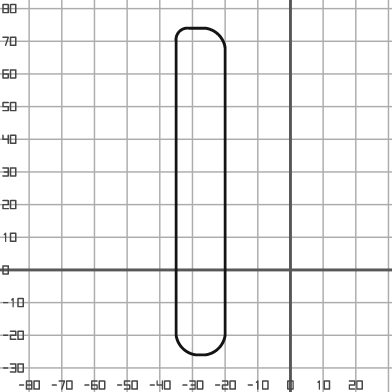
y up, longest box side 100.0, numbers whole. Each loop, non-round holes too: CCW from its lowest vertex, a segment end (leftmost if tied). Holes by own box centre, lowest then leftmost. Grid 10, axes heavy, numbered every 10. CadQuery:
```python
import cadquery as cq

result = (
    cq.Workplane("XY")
    .moveTo(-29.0, -26.0)
    .lineTo(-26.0, -26.0)
    .threePointArc((-22.0, -24.0), (-20.0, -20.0))
    .lineTo(-20.0, 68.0)
    .threePointArc((-22.0, 72.0), (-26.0, 74.0))
    .lineTo(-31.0, 74.0)
    .threePointArc((-34.0, 73.0), (-35.0, 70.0))
    .lineTo(-35.0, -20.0)
    .threePointArc((-33.0, -24.0), (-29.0, -26.0))
    .close()
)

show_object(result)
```